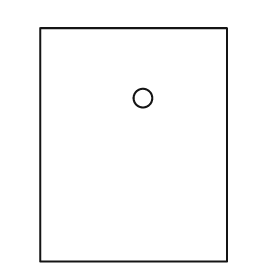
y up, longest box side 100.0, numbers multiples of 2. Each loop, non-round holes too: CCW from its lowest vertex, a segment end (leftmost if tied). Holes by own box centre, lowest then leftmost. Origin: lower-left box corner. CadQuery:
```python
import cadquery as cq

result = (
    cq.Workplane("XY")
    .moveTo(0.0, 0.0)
    .lineTo(80.0, 0.0)
    .lineTo(80.0, 100.0)
    .lineTo(0.0, 100.0)
    .close()
    .moveTo(44.0, 70.0)
    .circle(4.0)
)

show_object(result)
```